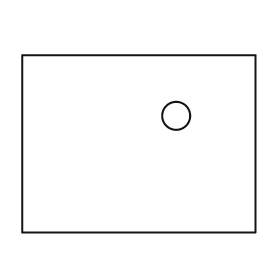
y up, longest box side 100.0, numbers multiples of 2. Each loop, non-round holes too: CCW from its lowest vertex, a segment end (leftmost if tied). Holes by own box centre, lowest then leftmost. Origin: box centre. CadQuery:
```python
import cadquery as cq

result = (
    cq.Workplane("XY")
    .moveTo(-50.0, -38.0)
    .lineTo(50.0, -38.0)
    .lineTo(50.0, 38.0)
    .lineTo(-50.0, 38.0)
    .close()
    .moveTo(16.0, 12.0)
    .circle(6.0)
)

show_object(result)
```